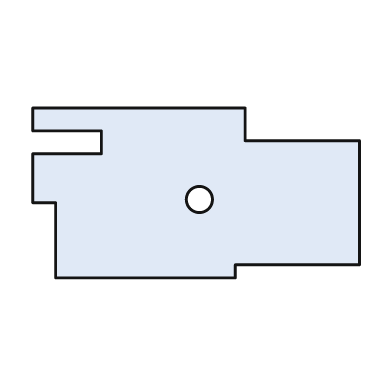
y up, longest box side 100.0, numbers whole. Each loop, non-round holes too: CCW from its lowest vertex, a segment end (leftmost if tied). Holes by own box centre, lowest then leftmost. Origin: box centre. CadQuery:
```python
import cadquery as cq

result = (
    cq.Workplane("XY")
    .moveTo(-43.0, -26.0)
    .lineTo(12.0, -26.0)
    .lineTo(12.0, -22.0)
    .lineTo(50.0, -22.0)
    .lineTo(50.0, 16.0)
    .lineTo(15.0, 16.0)
    .lineTo(15.0, 26.0)
    .lineTo(-50.0, 26.0)
    .lineTo(-50.0, 19.0)
    .lineTo(-29.0, 19.0)
    .lineTo(-29.0, 12.0)
    .lineTo(-50.0, 12.0)
    .lineTo(-50.0, -3.0)
    .lineTo(-43.0, -3.0)
    .close()
    .moveTo(1.0, -2.0)
    .circle(4.0)
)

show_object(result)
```